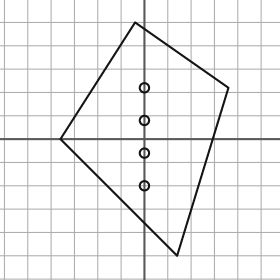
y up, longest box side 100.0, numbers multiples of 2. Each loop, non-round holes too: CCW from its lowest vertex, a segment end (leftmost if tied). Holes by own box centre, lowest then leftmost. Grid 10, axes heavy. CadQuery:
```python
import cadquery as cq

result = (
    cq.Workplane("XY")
    .moveTo(14.0, -50.0)
    .lineTo(36.0, 22.0)
    .lineTo(-4.0, 50.0)
    .lineTo(-36.0, 0.0)
    .close()
    .moveTo(0.0, -20.0)
    .circle(2.0)
    .moveTo(0.0, -6.0)
    .circle(2.0)
    .moveTo(0.0, 8.0)
    .circle(2.0)
    .moveTo(0.0, 22.0)
    .circle(2.0)
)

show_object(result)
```